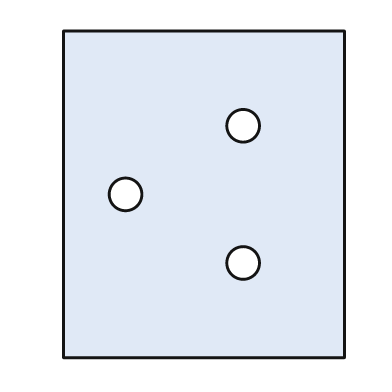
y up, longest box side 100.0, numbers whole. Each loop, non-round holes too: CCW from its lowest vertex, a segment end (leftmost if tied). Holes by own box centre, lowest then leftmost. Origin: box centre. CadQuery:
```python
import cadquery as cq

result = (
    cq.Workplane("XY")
    .moveTo(-43.0, -50.0)
    .lineTo(43.0, -50.0)
    .lineTo(43.0, 50.0)
    .lineTo(-43.0, 50.0)
    .close()
    .moveTo(12.0, -21.0)
    .circle(5.0)
    .moveTo(-24.0, 0.0)
    .circle(5.0)
    .moveTo(12.0, 21.0)
    .circle(5.0)
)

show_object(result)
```